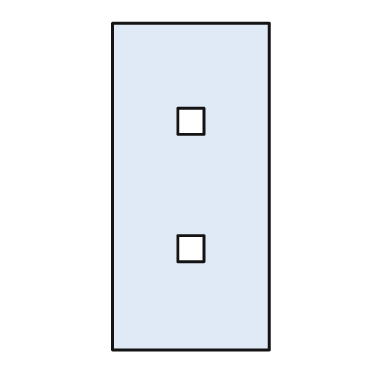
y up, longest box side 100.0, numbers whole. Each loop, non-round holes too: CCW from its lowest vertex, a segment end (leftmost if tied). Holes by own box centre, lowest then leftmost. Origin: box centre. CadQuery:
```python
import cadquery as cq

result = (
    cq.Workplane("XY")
    .moveTo(-24.0, -50.0)
    .lineTo(24.0, -50.0)
    .lineTo(24.0, 50.0)
    .lineTo(-24.0, 50.0)
    .close()
    .moveTo(-4.0, -23.0)
    .lineTo(4.0, -23.0)
    .lineTo(4.0, -15.0)
    .lineTo(-4.0, -15.0)
    .close()
    .moveTo(-4.0, 16.0)
    .lineTo(4.0, 16.0)
    .lineTo(4.0, 24.0)
    .lineTo(-4.0, 24.0)
    .close()
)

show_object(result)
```